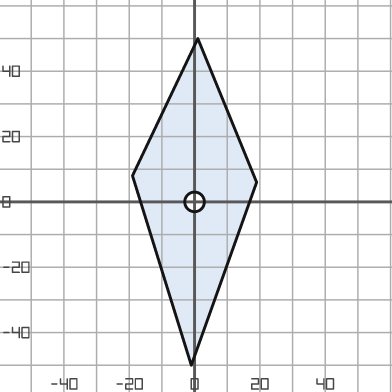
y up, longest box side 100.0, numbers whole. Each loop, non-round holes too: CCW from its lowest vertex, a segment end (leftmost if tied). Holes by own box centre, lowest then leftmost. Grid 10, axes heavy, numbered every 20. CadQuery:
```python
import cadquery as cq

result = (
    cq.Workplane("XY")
    .moveTo(-1.0, -50.0)
    .lineTo(19.0, 6.0)
    .lineTo(1.0, 50.0)
    .lineTo(-19.0, 8.0)
    .close()
    .moveTo(0.0, 0.0)
    .circle(3.0)
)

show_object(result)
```